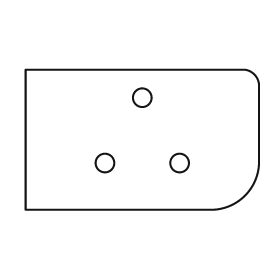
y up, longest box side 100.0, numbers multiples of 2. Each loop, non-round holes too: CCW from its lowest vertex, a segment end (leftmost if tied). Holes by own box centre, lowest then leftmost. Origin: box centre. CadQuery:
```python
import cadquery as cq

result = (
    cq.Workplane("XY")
    .moveTo(-50.0, -30.0)
    .lineTo(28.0, -30.0)
    .threePointArc((44.0, -24.0), (50.0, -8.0))
    .lineTo(50.0, 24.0)
    .threePointArc((48.0, 28.0), (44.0, 30.0))
    .lineTo(-50.0, 30.0)
    .close()
    .moveTo(-16.0, -10.0)
    .circle(4.0)
    .moveTo(16.0, -10.0)
    .circle(4.0)
    .moveTo(0.0, 18.0)
    .circle(4.0)
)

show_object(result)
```